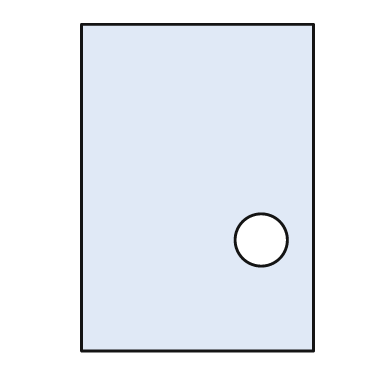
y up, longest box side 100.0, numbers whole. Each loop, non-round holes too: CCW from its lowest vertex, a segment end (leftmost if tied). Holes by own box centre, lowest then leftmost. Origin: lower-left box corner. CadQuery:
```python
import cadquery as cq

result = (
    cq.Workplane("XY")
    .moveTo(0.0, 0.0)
    .lineTo(71.0, 0.0)
    .lineTo(71.0, 100.0)
    .lineTo(0.0, 100.0)
    .close()
    .moveTo(55.0, 34.0)
    .circle(8.0)
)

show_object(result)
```